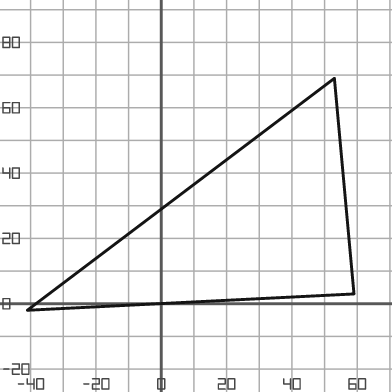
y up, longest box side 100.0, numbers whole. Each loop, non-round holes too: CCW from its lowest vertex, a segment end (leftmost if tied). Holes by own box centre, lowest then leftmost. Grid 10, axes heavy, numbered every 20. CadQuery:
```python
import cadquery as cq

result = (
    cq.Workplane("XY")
    .moveTo(-41.0, -2.0)
    .lineTo(59.0, 3.0)
    .lineTo(53.0, 69.0)
    .close()
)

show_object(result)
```